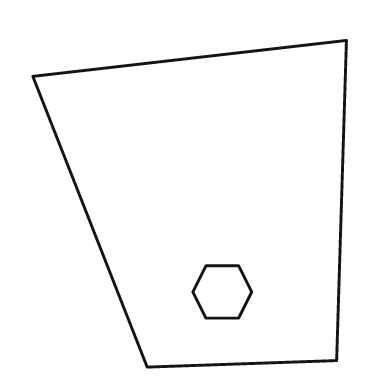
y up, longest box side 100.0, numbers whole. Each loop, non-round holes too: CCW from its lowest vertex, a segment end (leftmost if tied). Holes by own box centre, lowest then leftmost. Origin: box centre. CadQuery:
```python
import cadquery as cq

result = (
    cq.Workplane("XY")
    .moveTo(-13.0, -50.0)
    .lineTo(45.0, -48.0)
    .lineTo(48.0, 50.0)
    .lineTo(-48.0, 39.0)
    .close()
    .moveTo(5.0, -35.0)
    .lineTo(15.0, -35.0)
    .lineTo(19.0, -27.0)
    .lineTo(15.0, -19.0)
    .lineTo(5.0, -19.0)
    .lineTo(1.0, -27.0)
    .close()
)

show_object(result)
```